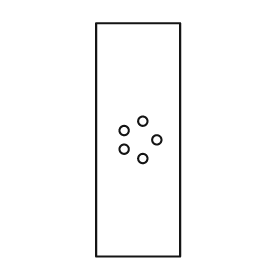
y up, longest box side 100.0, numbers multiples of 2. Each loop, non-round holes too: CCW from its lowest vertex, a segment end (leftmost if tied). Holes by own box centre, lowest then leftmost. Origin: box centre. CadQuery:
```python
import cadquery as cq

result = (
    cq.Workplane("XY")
    .moveTo(-18.0, -50.0)
    .lineTo(18.0, -50.0)
    .lineTo(18.0, 50.0)
    .lineTo(-18.0, 50.0)
    .close()
    .moveTo(2.0, -8.0)
    .circle(2.0)
    .moveTo(-6.0, -4.0)
    .circle(2.0)
    .moveTo(8.0, 0.0)
    .circle(2.0)
    .moveTo(-6.0, 4.0)
    .circle(2.0)
    .moveTo(2.0, 8.0)
    .circle(2.0)
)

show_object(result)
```